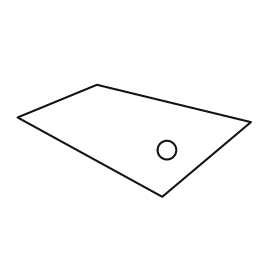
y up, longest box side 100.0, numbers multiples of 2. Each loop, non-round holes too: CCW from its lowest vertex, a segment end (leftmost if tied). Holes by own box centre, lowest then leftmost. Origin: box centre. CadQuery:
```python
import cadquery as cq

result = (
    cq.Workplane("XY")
    .moveTo(12.0, -24.0)
    .lineTo(50.0, 8.0)
    .lineTo(-16.0, 24.0)
    .lineTo(-50.0, 10.0)
    .close()
    .moveTo(14.0, -4.0)
    .circle(4.0)
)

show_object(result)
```